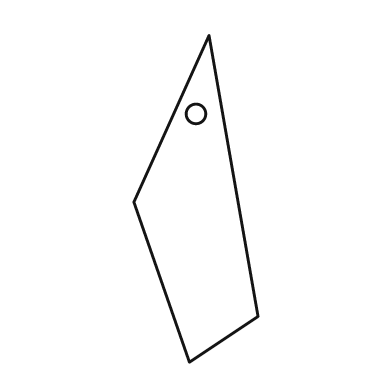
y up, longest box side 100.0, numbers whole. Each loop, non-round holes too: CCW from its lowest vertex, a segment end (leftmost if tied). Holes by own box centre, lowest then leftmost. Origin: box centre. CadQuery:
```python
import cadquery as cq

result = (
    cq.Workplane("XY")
    .moveTo(-2.0, -50.0)
    .lineTo(19.0, -36.0)
    .lineTo(4.0, 50.0)
    .lineTo(-19.0, -1.0)
    .close()
    .moveTo(0.0, 26.0)
    .circle(3.0)
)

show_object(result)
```